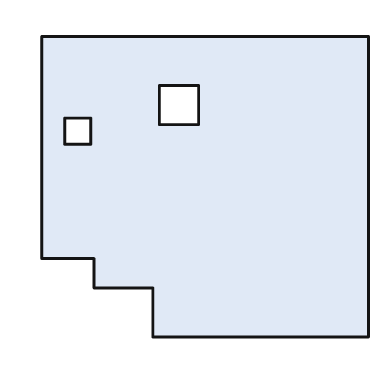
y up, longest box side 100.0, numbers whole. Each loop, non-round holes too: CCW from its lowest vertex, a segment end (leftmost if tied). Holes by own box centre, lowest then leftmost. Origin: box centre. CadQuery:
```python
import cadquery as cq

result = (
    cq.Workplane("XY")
    .moveTo(-16.0, -46.0)
    .lineTo(50.0, -46.0)
    .lineTo(50.0, 46.0)
    .lineTo(-50.0, 46.0)
    .lineTo(-50.0, -22.0)
    .lineTo(-34.0, -22.0)
    .lineTo(-34.0, -31.0)
    .lineTo(-16.0, -31.0)
    .close()
    .moveTo(-43.0, 13.0)
    .lineTo(-35.0, 13.0)
    .lineTo(-35.0, 21.0)
    .lineTo(-43.0, 21.0)
    .close()
    .moveTo(-14.0, 19.0)
    .lineTo(-2.0, 19.0)
    .lineTo(-2.0, 31.0)
    .lineTo(-14.0, 31.0)
    .close()
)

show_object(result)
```